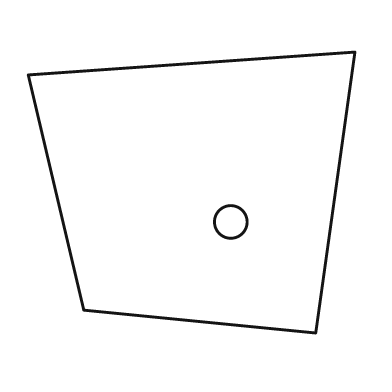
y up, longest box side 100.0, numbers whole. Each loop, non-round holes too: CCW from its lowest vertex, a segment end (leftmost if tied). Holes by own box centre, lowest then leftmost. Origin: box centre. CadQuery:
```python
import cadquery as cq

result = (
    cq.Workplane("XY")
    .moveTo(38.0, -43.0)
    .lineTo(50.0, 43.0)
    .lineTo(-50.0, 36.0)
    .lineTo(-33.0, -36.0)
    .close()
    .moveTo(12.0, -9.0)
    .circle(5.0)
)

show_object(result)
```